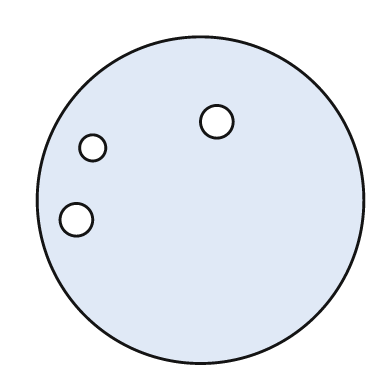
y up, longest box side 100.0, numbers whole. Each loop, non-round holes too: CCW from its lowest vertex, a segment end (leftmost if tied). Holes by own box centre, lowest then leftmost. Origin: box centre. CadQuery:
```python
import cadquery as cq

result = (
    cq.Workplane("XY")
    .moveTo(0.0, 0.0)
    .circle(50.0)
    .moveTo(-38.0, -6.0)
    .circle(5.0)
    .moveTo(-33.0, 16.0)
    .circle(4.0)
    .moveTo(5.0, 24.0)
    .circle(5.0)
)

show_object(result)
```